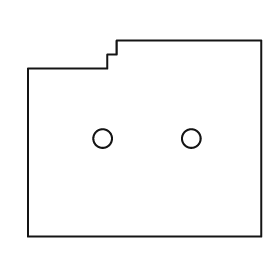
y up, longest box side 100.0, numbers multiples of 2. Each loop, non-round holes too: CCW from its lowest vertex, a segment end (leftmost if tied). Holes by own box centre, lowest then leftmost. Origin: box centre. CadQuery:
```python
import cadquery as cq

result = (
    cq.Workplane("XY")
    .moveTo(-50.0, -42.0)
    .lineTo(50.0, -42.0)
    .lineTo(50.0, 42.0)
    .lineTo(-12.0, 42.0)
    .lineTo(-12.0, 36.0)
    .lineTo(-16.0, 36.0)
    .lineTo(-16.0, 30.0)
    .lineTo(-50.0, 30.0)
    .close()
    .moveTo(-18.0, 0.0)
    .circle(4.0)
    .moveTo(20.0, 0.0)
    .circle(4.0)
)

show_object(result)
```